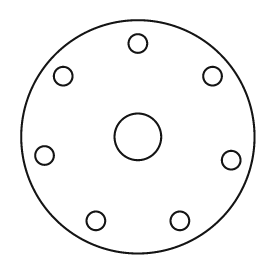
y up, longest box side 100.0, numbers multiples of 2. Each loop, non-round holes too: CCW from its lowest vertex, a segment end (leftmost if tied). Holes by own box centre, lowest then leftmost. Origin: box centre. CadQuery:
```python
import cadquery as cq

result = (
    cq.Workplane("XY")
    .moveTo(0.0, 0.0)
    .circle(50.0)
    .moveTo(-18.0, -36.0)
    .circle(4.0)
    .moveTo(18.0, -36.0)
    .circle(4.0)
    .moveTo(40.0, -10.0)
    .circle(4.0)
    .moveTo(-40.0, -8.0)
    .circle(4.0)
    .moveTo(0.0, 0.0)
    .circle(10.0)
    .moveTo(-32.0, 26.0)
    .circle(4.0)
    .moveTo(32.0, 26.0)
    .circle(4.0)
    .moveTo(0.0, 40.0)
    .circle(4.0)
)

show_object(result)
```